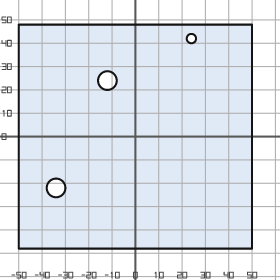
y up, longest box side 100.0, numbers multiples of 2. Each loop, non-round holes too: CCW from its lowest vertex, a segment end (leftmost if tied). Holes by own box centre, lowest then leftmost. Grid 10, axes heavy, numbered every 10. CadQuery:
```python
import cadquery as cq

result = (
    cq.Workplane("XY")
    .moveTo(-50.0, -48.0)
    .lineTo(50.0, -48.0)
    .lineTo(50.0, 48.0)
    .lineTo(-50.0, 48.0)
    .close()
    .moveTo(-34.0, -22.0)
    .circle(4.0)
    .moveTo(-12.0, 24.0)
    .circle(4.0)
    .moveTo(24.0, 42.0)
    .circle(2.0)
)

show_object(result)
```